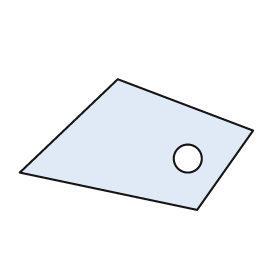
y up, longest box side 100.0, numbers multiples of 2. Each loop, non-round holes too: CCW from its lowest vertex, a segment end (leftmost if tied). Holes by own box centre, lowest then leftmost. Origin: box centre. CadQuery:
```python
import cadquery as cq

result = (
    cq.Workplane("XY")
    .moveTo(26.0, -28.0)
    .lineTo(50.0, 6.0)
    .lineTo(-8.0, 28.0)
    .lineTo(-50.0, -12.0)
    .close()
    .moveTo(22.0, -6.0)
    .circle(6.0)
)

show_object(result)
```